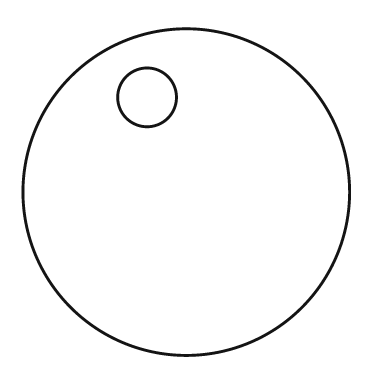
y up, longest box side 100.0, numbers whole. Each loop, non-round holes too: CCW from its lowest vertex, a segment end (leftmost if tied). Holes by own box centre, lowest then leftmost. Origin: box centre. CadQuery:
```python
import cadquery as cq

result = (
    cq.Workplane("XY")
    .moveTo(0.0, 0.0)
    .circle(50.0)
    .moveTo(-12.0, 29.0)
    .circle(9.0)
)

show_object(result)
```